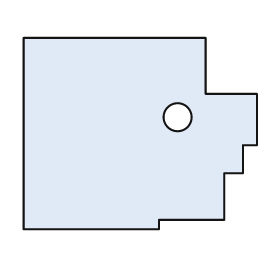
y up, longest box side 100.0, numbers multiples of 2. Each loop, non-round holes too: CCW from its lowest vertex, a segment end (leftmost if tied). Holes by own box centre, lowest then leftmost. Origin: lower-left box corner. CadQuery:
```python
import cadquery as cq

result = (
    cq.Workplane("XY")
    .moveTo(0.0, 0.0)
    .lineTo(58.0, 0.0)
    .lineTo(58.0, 4.0)
    .lineTo(86.0, 4.0)
    .lineTo(86.0, 24.0)
    .lineTo(94.0, 24.0)
    .lineTo(94.0, 36.0)
    .lineTo(100.0, 36.0)
    .lineTo(100.0, 58.0)
    .lineTo(78.0, 58.0)
    .lineTo(78.0, 82.0)
    .lineTo(0.0, 82.0)
    .close()
    .moveTo(66.0, 48.0)
    .circle(6.0)
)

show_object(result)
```